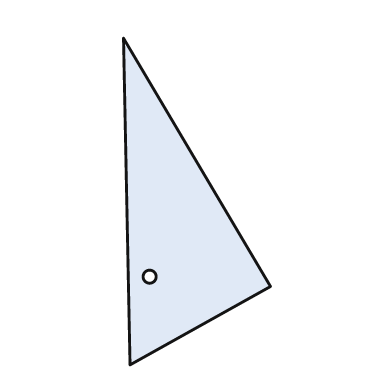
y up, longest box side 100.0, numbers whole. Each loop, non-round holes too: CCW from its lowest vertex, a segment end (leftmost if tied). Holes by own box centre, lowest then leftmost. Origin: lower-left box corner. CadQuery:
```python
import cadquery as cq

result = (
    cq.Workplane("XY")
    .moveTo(2.0, 0.0)
    .lineTo(45.0, 24.0)
    .lineTo(0.0, 100.0)
    .close()
    .moveTo(8.0, 27.0)
    .circle(2.0)
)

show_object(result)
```